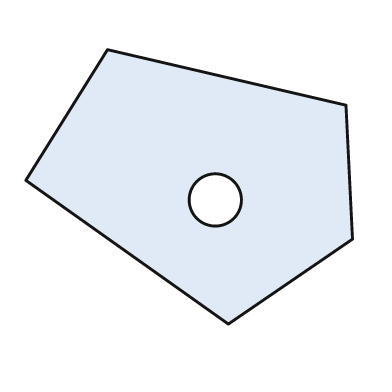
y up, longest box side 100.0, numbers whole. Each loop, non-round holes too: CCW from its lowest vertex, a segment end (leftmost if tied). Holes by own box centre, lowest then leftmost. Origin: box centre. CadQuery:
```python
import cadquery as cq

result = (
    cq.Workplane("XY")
    .moveTo(12.0, -42.0)
    .lineTo(50.0, -16.0)
    .lineTo(48.0, 25.0)
    .lineTo(-25.0, 42.0)
    .lineTo(-50.0, 2.0)
    .close()
    .moveTo(8.0, -4.0)
    .circle(8.0)
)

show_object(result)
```